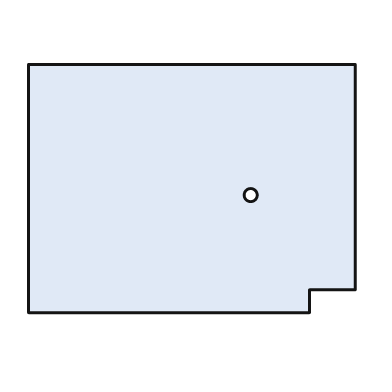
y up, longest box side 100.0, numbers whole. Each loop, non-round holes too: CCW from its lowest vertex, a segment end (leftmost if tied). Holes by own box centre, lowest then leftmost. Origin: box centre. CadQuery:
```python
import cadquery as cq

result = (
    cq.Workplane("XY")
    .moveTo(-50.0, -38.0)
    .lineTo(36.0, -38.0)
    .lineTo(36.0, -31.0)
    .lineTo(50.0, -31.0)
    .lineTo(50.0, 38.0)
    .lineTo(-50.0, 38.0)
    .close()
    .moveTo(18.0, -2.0)
    .circle(2.0)
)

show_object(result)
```